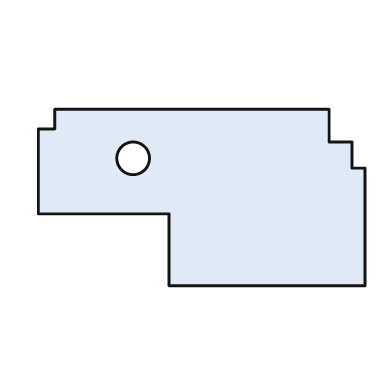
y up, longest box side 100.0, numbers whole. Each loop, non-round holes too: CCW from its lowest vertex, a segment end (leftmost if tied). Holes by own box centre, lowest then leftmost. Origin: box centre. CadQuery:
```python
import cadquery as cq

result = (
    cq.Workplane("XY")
    .moveTo(-10.0, -27.0)
    .lineTo(50.0, -27.0)
    .lineTo(50.0, 9.0)
    .lineTo(46.0, 9.0)
    .lineTo(46.0, 17.0)
    .lineTo(39.0, 17.0)
    .lineTo(39.0, 27.0)
    .lineTo(-45.0, 27.0)
    .lineTo(-45.0, 21.0)
    .lineTo(-50.0, 21.0)
    .lineTo(-50.0, -5.0)
    .lineTo(-10.0, -5.0)
    .close()
    .moveTo(-21.0, 12.0)
    .circle(5.0)
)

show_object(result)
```